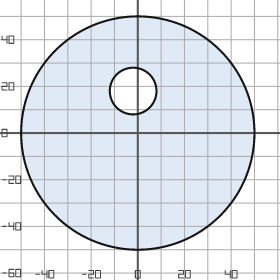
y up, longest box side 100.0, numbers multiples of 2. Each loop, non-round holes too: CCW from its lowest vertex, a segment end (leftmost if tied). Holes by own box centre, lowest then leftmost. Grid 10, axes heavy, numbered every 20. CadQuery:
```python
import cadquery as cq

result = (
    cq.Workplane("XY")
    .moveTo(0.0, 0.0)
    .circle(50.0)
    .moveTo(-2.0, 18.0)
    .circle(10.0)
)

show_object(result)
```